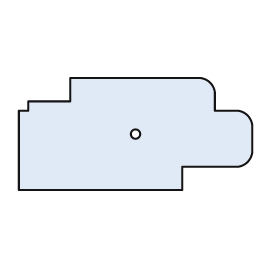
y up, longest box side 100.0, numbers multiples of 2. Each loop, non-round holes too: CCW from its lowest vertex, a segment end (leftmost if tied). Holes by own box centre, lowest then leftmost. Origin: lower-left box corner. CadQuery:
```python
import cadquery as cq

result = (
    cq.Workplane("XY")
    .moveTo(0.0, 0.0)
    .lineTo(70.0, 0.0)
    .lineTo(70.0, 10.0)
    .lineTo(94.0, 10.0)
    .threePointArc((98.0, 12.0), (100.0, 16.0))
    .lineTo(100.0, 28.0)
    .threePointArc((98.0, 32.0), (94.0, 34.0))
    .lineTo(84.0, 34.0)
    .lineTo(84.0, 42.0)
    .threePointArc((82.0, 46.0), (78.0, 48.0))
    .lineTo(22.0, 48.0)
    .lineTo(22.0, 38.0)
    .lineTo(4.0, 38.0)
    .lineTo(4.0, 34.0)
    .lineTo(0.0, 34.0)
    .close()
    .moveTo(50.0, 24.0)
    .circle(2.0)
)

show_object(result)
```